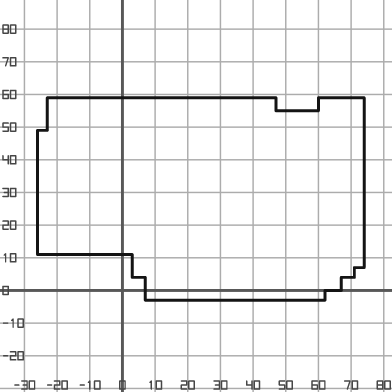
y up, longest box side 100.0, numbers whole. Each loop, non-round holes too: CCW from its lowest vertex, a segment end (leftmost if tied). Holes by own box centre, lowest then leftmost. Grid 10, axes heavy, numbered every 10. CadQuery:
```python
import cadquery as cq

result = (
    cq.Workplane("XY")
    .moveTo(7.0, -3.0)
    .lineTo(62.0, -3.0)
    .lineTo(62.0, 0.0)
    .lineTo(67.0, 0.0)
    .lineTo(67.0, 4.0)
    .lineTo(71.0, 4.0)
    .lineTo(71.0, 7.0)
    .lineTo(74.0, 7.0)
    .lineTo(74.0, 59.0)
    .lineTo(60.0, 59.0)
    .lineTo(60.0, 55.0)
    .lineTo(47.0, 55.0)
    .lineTo(47.0, 59.0)
    .lineTo(-23.0, 59.0)
    .lineTo(-23.0, 49.0)
    .lineTo(-26.0, 49.0)
    .lineTo(-26.0, 11.0)
    .lineTo(3.0, 11.0)
    .lineTo(3.0, 4.0)
    .lineTo(7.0, 4.0)
    .close()
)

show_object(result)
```